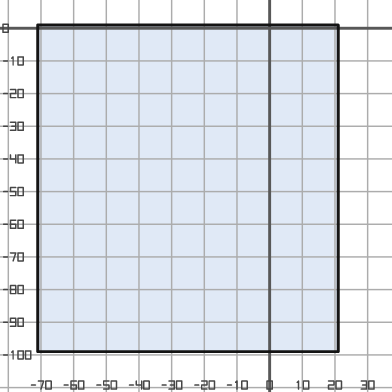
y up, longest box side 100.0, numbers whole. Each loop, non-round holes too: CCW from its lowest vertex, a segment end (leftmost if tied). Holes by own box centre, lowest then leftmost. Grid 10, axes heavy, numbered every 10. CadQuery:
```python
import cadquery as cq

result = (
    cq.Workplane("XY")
    .moveTo(-71.0, -99.0)
    .lineTo(21.0, -99.0)
    .lineTo(21.0, 1.0)
    .lineTo(-71.0, 1.0)
    .close()
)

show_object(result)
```